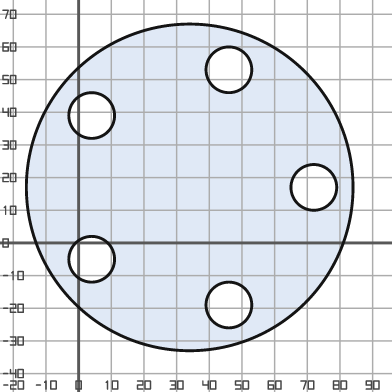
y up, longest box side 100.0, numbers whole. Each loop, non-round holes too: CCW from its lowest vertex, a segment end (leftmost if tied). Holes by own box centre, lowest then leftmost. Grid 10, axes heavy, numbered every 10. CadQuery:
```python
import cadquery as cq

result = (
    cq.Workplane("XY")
    .moveTo(34.0, 17.0)
    .circle(50.0)
    .moveTo(46.0, -19.0)
    .circle(7.0)
    .moveTo(4.0, -5.0)
    .circle(7.0)
    .moveTo(72.0, 17.0)
    .circle(7.0)
    .moveTo(4.0, 39.0)
    .circle(7.0)
    .moveTo(46.0, 53.0)
    .circle(7.0)
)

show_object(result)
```